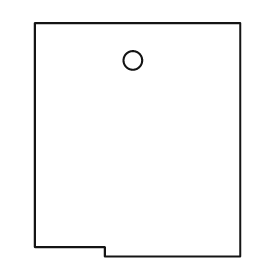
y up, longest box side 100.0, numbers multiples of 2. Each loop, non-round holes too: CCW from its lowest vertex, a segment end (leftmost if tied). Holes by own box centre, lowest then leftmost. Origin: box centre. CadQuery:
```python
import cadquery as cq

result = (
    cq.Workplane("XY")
    .moveTo(-14.0, -50.0)
    .lineTo(44.0, -50.0)
    .lineTo(44.0, 50.0)
    .lineTo(-44.0, 50.0)
    .lineTo(-44.0, -46.0)
    .lineTo(-14.0, -46.0)
    .close()
    .moveTo(-2.0, 34.0)
    .circle(4.0)
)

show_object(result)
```